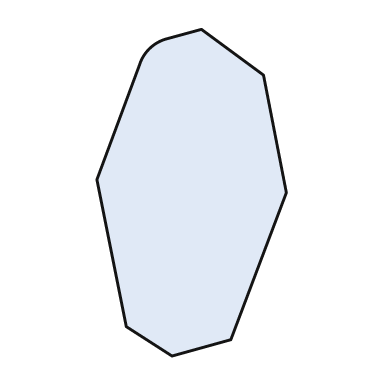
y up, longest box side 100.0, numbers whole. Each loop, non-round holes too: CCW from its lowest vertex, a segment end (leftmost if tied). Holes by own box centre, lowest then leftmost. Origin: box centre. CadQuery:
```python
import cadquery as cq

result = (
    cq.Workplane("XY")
    .moveTo(-6.0, -50.0)
    .lineTo(12.0, -45.0)
    .lineTo(29.0, 0.0)
    .lineTo(22.0, 36.0)
    .lineTo(3.0, 50.0)
    .lineTo(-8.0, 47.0)
    .threePointArc((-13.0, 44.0), (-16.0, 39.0))
    .lineTo(-29.0, 4.0)
    .lineTo(-20.0, -41.0)
    .close()
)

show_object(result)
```